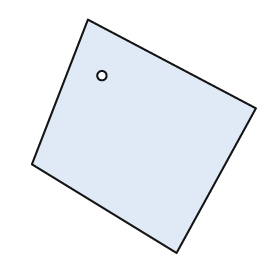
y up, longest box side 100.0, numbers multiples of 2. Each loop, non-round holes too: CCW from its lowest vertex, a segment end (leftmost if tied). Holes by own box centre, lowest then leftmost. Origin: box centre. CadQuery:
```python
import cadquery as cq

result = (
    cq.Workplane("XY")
    .moveTo(14.0, -50.0)
    .lineTo(48.0, 12.0)
    .lineTo(-24.0, 50.0)
    .lineTo(-48.0, -12.0)
    .close()
    .moveTo(-18.0, 26.0)
    .circle(2.0)
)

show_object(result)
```